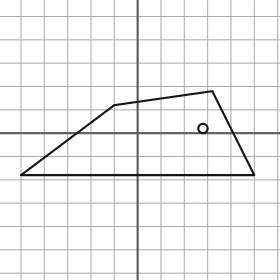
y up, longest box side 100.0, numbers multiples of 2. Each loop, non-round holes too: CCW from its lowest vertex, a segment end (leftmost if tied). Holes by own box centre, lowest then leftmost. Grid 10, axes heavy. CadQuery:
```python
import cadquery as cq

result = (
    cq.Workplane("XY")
    .moveTo(-50.0, -18.0)
    .lineTo(50.0, -18.0)
    .lineTo(32.0, 18.0)
    .lineTo(-10.0, 12.0)
    .close()
    .moveTo(28.0, 2.0)
    .circle(2.0)
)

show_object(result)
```